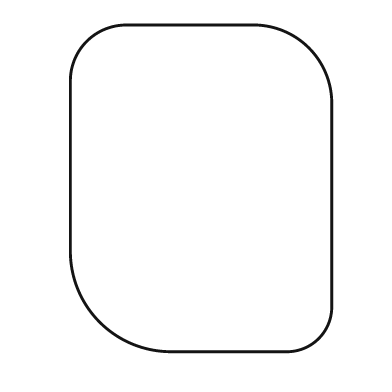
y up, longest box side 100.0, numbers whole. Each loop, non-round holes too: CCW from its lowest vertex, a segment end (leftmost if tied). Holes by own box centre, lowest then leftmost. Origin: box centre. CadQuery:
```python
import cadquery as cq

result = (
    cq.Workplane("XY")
    .moveTo(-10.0, -50.0)
    .lineTo(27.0, -50.0)
    .threePointArc((36.0, -46.0), (40.0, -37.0))
    .lineTo(40.0, 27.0)
    .threePointArc((33.0, 43.0), (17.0, 50.0))
    .lineTo(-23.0, 50.0)
    .threePointArc((-35.0, 45.0), (-40.0, 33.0))
    .lineTo(-40.0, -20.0)
    .threePointArc((-31.0, -41.0), (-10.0, -50.0))
    .close()
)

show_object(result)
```